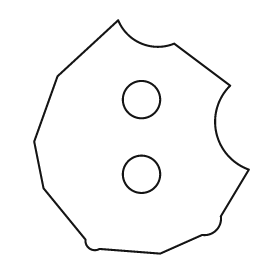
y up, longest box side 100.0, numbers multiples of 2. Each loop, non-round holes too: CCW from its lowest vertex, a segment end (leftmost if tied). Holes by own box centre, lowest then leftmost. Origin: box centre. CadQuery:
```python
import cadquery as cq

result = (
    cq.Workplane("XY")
    .moveTo(8.0, -50.0)
    .lineTo(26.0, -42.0)
    .threePointArc((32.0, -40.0), (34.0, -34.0))
    .lineTo(46.0, -14.0)
    .threePointArc((32.0, 2.0), (38.0, 22.0))
    .lineTo(14.0, 40.0)
    .threePointArc((0.0, 40.0), (-10.0, 50.0))
    .lineTo(-36.0, 26.0)
    .lineTo(-46.0, -2.0)
    .lineTo(-42.0, -22.0)
    .lineTo(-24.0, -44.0)
    .threePointArc((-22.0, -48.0), (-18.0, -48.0))
    .close()
    .moveTo(0.0, -16.0)
    .circle(8.0)
    .moveTo(0.0, 16.0)
    .circle(8.0)
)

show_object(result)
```